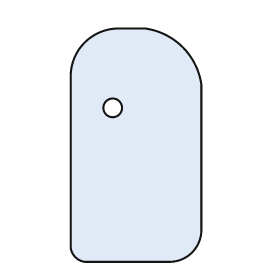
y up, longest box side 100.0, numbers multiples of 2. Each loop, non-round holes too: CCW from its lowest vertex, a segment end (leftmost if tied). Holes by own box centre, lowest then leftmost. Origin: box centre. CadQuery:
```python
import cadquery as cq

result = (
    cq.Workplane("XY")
    .moveTo(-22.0, -50.0)
    .lineTo(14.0, -50.0)
    .threePointArc((24.0, -46.0), (28.0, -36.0))
    .lineTo(28.0, 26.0)
    .threePointArc((20.0, 42.0), (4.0, 50.0))
    .lineTo(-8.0, 50.0)
    .threePointArc((-22.0, 44.0), (-28.0, 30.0))
    .lineTo(-28.0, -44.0)
    .threePointArc((-26.0, -48.0), (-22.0, -50.0))
    .close()
    .moveTo(-10.0, 16.0)
    .circle(4.0)
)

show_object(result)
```